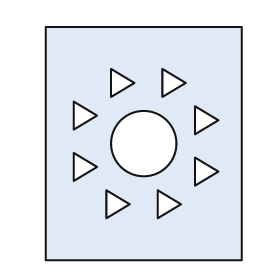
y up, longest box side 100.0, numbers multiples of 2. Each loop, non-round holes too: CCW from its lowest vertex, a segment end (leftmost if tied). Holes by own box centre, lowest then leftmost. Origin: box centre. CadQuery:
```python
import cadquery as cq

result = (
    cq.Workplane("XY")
    .moveTo(-42.0, -50.0)
    .lineTo(42.0, -50.0)
    .lineTo(42.0, 50.0)
    .lineTo(-42.0, 50.0)
    .close()
    .moveTo(-16.0, -32.0)
    .lineTo(-6.0, -26.0)
    .lineTo(-16.0, -20.0)
    .close()
    .moveTo(6.0, -32.0)
    .lineTo(16.0, -26.0)
    .lineTo(6.0, -20.0)
    .close()
    .moveTo(22.0, -18.0)
    .lineTo(32.0, -12.0)
    .lineTo(22.0, -6.0)
    .close()
    .moveTo(-30.0, -16.0)
    .lineTo(-20.0, -10.0)
    .lineTo(-30.0, -4.0)
    .close()
    .moveTo(0.0, 0.0)
    .circle(14.0)
    .moveTo(22.0, 4.0)
    .lineTo(32.0, 10.0)
    .lineTo(22.0, 16.0)
    .close()
    .moveTo(-30.0, 6.0)
    .lineTo(-20.0, 12.0)
    .lineTo(-30.0, 18.0)
    .close()
    .moveTo(-14.0, 20.0)
    .lineTo(-4.0, 26.0)
    .lineTo(-14.0, 32.0)
    .close()
    .moveTo(8.0, 20.0)
    .lineTo(18.0, 26.0)
    .lineTo(8.0, 32.0)
    .close()
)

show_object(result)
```